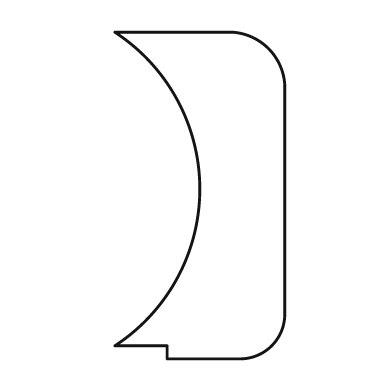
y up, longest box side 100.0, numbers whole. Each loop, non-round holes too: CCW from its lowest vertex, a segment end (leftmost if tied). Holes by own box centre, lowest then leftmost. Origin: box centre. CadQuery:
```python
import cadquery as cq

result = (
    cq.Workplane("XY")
    .moveTo(-10.0, -50.0)
    .lineTo(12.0, -50.0)
    .threePointArc((22.0, -46.0), (26.0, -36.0))
    .lineTo(26.0, 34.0)
    .threePointArc((21.0, 45.0), (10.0, 50.0))
    .lineTo(-26.0, 50.0)
    .threePointArc((0.0, 2.0), (-26.0, -46.0))
    .lineTo(-10.0, -46.0)
    .close()
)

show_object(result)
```